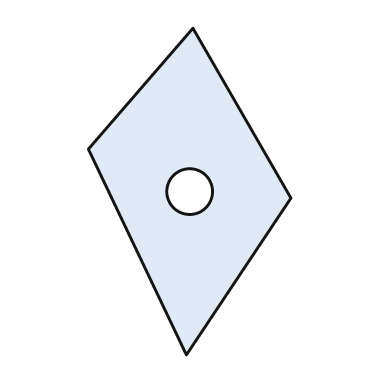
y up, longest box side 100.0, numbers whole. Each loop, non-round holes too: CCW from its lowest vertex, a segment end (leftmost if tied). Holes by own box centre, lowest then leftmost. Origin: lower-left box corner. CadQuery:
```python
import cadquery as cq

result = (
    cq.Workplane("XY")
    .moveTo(30.0, 0.0)
    .lineTo(62.0, 48.0)
    .lineTo(32.0, 100.0)
    .lineTo(0.0, 63.0)
    .close()
    .moveTo(31.0, 50.0)
    .circle(7.0)
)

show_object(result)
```